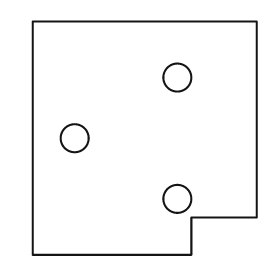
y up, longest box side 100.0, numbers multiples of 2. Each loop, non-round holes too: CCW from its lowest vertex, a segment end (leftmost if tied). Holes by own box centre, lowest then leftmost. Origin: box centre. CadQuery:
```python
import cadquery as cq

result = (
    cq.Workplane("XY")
    .moveTo(-48.0, -50.0)
    .lineTo(20.0, -50.0)
    .lineTo(20.0, -34.0)
    .lineTo(48.0, -34.0)
    .lineTo(48.0, 50.0)
    .lineTo(-48.0, 50.0)
    .close()
    .moveTo(14.0, -26.0)
    .circle(6.0)
    .moveTo(-30.0, 0.0)
    .circle(6.0)
    .moveTo(14.0, 26.0)
    .circle(6.0)
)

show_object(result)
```